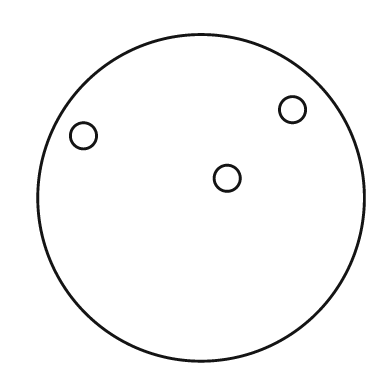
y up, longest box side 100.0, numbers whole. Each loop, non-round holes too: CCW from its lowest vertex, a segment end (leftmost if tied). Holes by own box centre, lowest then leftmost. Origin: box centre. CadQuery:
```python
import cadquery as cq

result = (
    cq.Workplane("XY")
    .moveTo(0.0, 0.0)
    .circle(50.0)
    .moveTo(8.0, 6.0)
    .circle(4.0)
    .moveTo(-36.0, 19.0)
    .circle(4.0)
    .moveTo(28.0, 27.0)
    .circle(4.0)
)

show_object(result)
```